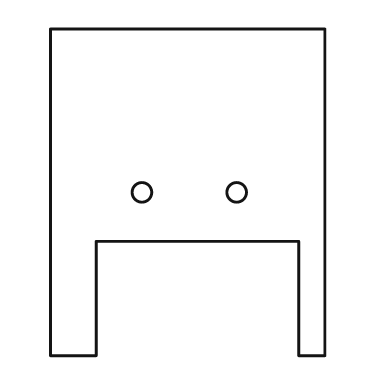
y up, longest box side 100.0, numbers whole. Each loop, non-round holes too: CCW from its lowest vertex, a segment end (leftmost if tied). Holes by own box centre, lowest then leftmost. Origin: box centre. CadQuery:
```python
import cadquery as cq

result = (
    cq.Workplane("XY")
    .moveTo(-42.0, -50.0)
    .lineTo(-28.0, -50.0)
    .lineTo(-28.0, -15.0)
    .lineTo(34.0, -15.0)
    .lineTo(34.0, -50.0)
    .lineTo(42.0, -50.0)
    .lineTo(42.0, 50.0)
    .lineTo(-42.0, 50.0)
    .close()
    .moveTo(-14.0, 0.0)
    .circle(3.0)
    .moveTo(15.0, 0.0)
    .circle(3.0)
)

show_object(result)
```